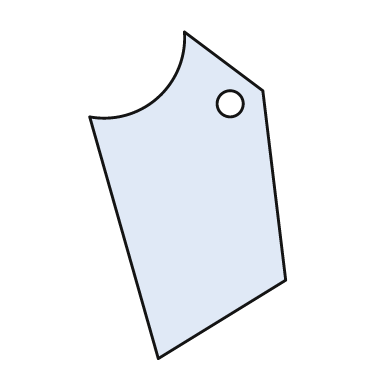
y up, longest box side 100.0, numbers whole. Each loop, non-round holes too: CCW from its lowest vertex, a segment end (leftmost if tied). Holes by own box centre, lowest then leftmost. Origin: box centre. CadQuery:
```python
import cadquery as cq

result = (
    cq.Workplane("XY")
    .moveTo(-9.0, -50.0)
    .lineTo(30.0, -26.0)
    .lineTo(23.0, 32.0)
    .lineTo(-1.0, 50.0)
    .threePointArc((-9.0, 30.0), (-30.0, 24.0))
    .close()
    .moveTo(13.0, 28.0)
    .circle(4.0)
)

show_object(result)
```